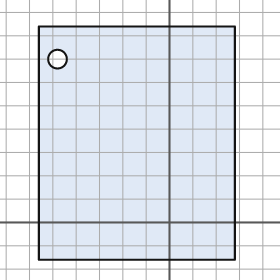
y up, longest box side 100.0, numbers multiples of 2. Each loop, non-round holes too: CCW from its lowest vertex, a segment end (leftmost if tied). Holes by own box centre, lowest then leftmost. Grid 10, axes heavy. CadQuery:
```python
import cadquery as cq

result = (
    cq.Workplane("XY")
    .moveTo(-56.0, -16.0)
    .lineTo(28.0, -16.0)
    .lineTo(28.0, 84.0)
    .lineTo(-56.0, 84.0)
    .close()
    .moveTo(-48.0, 70.0)
    .circle(4.0)
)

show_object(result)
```